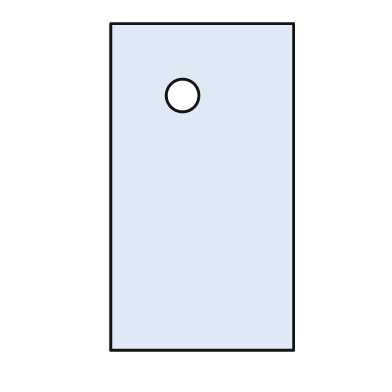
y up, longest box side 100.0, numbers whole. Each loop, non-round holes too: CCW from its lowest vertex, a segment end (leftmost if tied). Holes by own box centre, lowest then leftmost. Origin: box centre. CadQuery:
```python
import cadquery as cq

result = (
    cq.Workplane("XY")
    .moveTo(-28.0, -50.0)
    .lineTo(28.0, -50.0)
    .lineTo(28.0, 50.0)
    .lineTo(-28.0, 50.0)
    .close()
    .moveTo(-6.0, 28.0)
    .circle(5.0)
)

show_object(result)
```